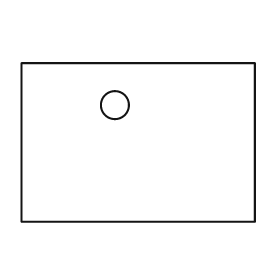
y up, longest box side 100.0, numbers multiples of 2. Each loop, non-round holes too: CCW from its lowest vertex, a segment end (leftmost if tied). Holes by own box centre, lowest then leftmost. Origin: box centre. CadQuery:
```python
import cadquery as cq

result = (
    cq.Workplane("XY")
    .moveTo(-50.0, -34.0)
    .lineTo(50.0, -34.0)
    .lineTo(50.0, 34.0)
    .lineTo(-50.0, 34.0)
    .close()
    .moveTo(-10.0, 16.0)
    .circle(6.0)
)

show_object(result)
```